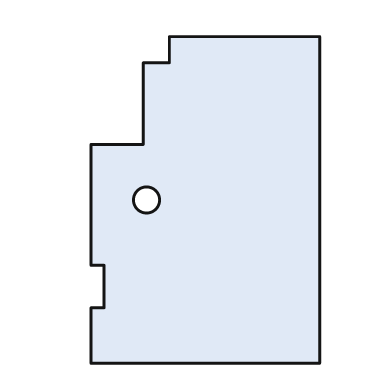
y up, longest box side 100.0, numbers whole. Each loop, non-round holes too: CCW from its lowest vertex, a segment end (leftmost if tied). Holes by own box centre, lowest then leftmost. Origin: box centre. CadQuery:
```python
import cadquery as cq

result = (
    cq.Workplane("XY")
    .moveTo(-35.0, -50.0)
    .lineTo(35.0, -50.0)
    .lineTo(35.0, 50.0)
    .lineTo(-11.0, 50.0)
    .lineTo(-11.0, 42.0)
    .lineTo(-19.0, 42.0)
    .lineTo(-19.0, 17.0)
    .lineTo(-35.0, 17.0)
    .lineTo(-35.0, -20.0)
    .lineTo(-31.0, -20.0)
    .lineTo(-31.0, -33.0)
    .lineTo(-35.0, -33.0)
    .close()
    .moveTo(-18.0, 0.0)
    .circle(4.0)
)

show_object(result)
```